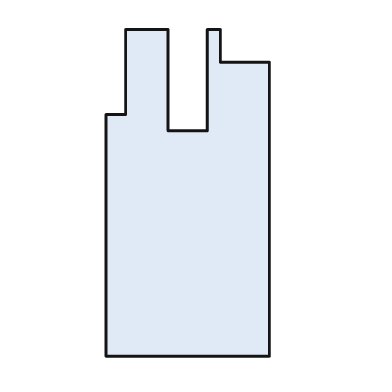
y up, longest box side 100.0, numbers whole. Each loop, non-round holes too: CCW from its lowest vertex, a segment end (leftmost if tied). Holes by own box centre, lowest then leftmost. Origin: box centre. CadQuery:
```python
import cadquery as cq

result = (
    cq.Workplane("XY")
    .moveTo(-25.0, -50.0)
    .lineTo(25.0, -50.0)
    .lineTo(25.0, 40.0)
    .lineTo(10.0, 40.0)
    .lineTo(10.0, 50.0)
    .lineTo(6.0, 50.0)
    .lineTo(6.0, 19.0)
    .lineTo(-6.0, 19.0)
    .lineTo(-6.0, 50.0)
    .lineTo(-19.0, 50.0)
    .lineTo(-19.0, 24.0)
    .lineTo(-25.0, 24.0)
    .close()
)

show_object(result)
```